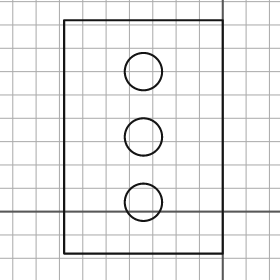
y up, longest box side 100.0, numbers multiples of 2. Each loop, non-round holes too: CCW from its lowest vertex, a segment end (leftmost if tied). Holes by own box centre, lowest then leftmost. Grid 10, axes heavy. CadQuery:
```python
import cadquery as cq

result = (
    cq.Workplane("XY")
    .moveTo(-68.0, -18.0)
    .lineTo(0.0, -18.0)
    .lineTo(0.0, 82.0)
    .lineTo(-68.0, 82.0)
    .close()
    .moveTo(-34.0, 4.0)
    .circle(8.0)
    .moveTo(-34.0, 32.0)
    .circle(8.0)
    .moveTo(-34.0, 60.0)
    .circle(8.0)
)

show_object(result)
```